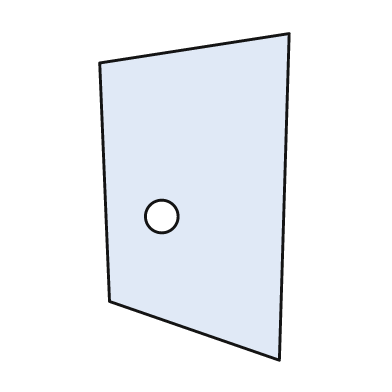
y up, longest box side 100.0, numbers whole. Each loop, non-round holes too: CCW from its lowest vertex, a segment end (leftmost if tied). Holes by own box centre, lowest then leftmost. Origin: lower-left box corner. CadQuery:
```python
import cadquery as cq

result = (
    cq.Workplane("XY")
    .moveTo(55.0, 0.0)
    .lineTo(58.0, 100.0)
    .lineTo(0.0, 91.0)
    .lineTo(3.0, 18.0)
    .close()
    .moveTo(19.0, 44.0)
    .circle(5.0)
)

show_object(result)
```